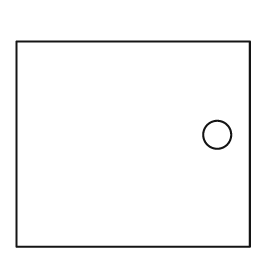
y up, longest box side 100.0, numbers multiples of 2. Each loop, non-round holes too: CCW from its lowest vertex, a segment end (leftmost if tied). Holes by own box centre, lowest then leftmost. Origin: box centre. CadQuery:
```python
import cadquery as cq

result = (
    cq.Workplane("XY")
    .moveTo(-50.0, -44.0)
    .lineTo(50.0, -44.0)
    .lineTo(50.0, 44.0)
    .lineTo(-50.0, 44.0)
    .close()
    .moveTo(36.0, 4.0)
    .circle(6.0)
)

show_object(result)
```